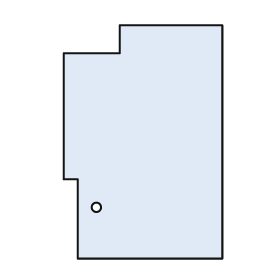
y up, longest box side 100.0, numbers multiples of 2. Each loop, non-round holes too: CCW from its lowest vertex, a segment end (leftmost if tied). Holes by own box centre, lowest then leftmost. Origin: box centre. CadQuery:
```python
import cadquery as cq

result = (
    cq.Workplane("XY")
    .moveTo(-28.0, -50.0)
    .lineTo(34.0, -50.0)
    .lineTo(34.0, 50.0)
    .lineTo(-10.0, 50.0)
    .lineTo(-10.0, 38.0)
    .lineTo(-34.0, 38.0)
    .lineTo(-34.0, -16.0)
    .lineTo(-28.0, -16.0)
    .close()
    .moveTo(-20.0, -28.0)
    .circle(2.0)
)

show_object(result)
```